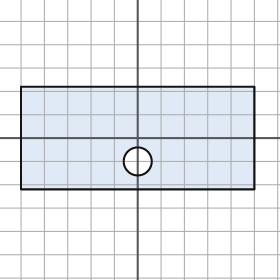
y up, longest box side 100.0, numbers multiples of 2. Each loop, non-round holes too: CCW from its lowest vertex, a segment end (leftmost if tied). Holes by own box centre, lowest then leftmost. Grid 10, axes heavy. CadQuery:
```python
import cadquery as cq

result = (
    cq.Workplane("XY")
    .moveTo(-50.0, -22.0)
    .lineTo(50.0, -22.0)
    .lineTo(50.0, 22.0)
    .lineTo(-50.0, 22.0)
    .close()
    .moveTo(0.0, -10.0)
    .circle(6.0)
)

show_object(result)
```